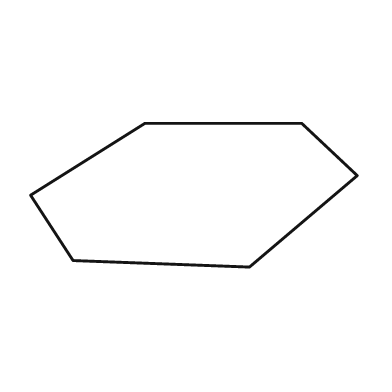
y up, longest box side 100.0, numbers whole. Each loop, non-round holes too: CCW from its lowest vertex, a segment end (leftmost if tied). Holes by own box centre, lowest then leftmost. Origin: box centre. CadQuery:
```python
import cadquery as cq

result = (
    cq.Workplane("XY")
    .moveTo(17.0, -22.0)
    .lineTo(50.0, 6.0)
    .lineTo(33.0, 22.0)
    .lineTo(-15.0, 22.0)
    .lineTo(-50.0, 0.0)
    .lineTo(-37.0, -20.0)
    .close()
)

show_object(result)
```